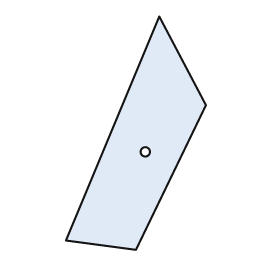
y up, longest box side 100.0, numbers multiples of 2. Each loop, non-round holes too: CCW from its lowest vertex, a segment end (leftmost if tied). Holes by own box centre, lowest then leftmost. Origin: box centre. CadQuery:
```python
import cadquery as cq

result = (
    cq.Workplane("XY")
    .moveTo(0.0, -50.0)
    .lineTo(30.0, 12.0)
    .lineTo(10.0, 50.0)
    .lineTo(-30.0, -46.0)
    .close()
    .moveTo(4.0, -8.0)
    .circle(2.0)
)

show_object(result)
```